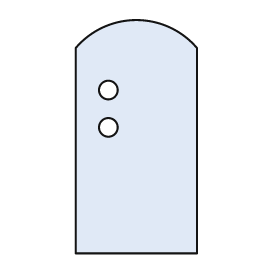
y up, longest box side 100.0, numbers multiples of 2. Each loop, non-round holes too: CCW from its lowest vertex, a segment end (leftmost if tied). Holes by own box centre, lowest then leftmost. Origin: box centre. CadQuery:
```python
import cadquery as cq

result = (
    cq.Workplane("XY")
    .moveTo(-26.0, -50.0)
    .lineTo(26.0, -50.0)
    .lineTo(26.0, 38.0)
    .threePointArc((0.0, 50.0), (-26.0, 38.0))
    .close()
    .moveTo(-12.0, 4.0)
    .circle(4.0)
    .moveTo(-12.0, 20.0)
    .circle(4.0)
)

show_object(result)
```